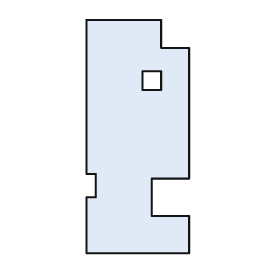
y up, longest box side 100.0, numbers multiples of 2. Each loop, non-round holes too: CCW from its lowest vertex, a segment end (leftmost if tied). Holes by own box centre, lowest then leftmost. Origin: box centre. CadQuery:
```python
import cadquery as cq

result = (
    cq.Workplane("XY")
    .moveTo(-22.0, -50.0)
    .lineTo(22.0, -50.0)
    .lineTo(22.0, -34.0)
    .lineTo(6.0, -34.0)
    .lineTo(6.0, -18.0)
    .lineTo(22.0, -18.0)
    .lineTo(22.0, 38.0)
    .lineTo(10.0, 38.0)
    .lineTo(10.0, 50.0)
    .lineTo(-22.0, 50.0)
    .lineTo(-22.0, -16.0)
    .lineTo(-18.0, -16.0)
    .lineTo(-18.0, -26.0)
    .lineTo(-22.0, -26.0)
    .close()
    .moveTo(2.0, 20.0)
    .lineTo(10.0, 20.0)
    .lineTo(10.0, 28.0)
    .lineTo(2.0, 28.0)
    .close()
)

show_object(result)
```